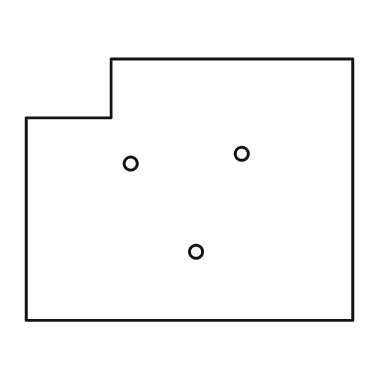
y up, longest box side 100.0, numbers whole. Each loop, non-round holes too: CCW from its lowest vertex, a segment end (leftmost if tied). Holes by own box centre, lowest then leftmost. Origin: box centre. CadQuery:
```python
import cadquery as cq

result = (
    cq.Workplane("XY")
    .moveTo(-50.0, -40.0)
    .lineTo(50.0, -40.0)
    .lineTo(50.0, 40.0)
    .lineTo(-24.0, 40.0)
    .lineTo(-24.0, 22.0)
    .lineTo(-50.0, 22.0)
    .close()
    .moveTo(2.0, -19.0)
    .circle(2.0)
    .moveTo(-18.0, 8.0)
    .circle(2.0)
    .moveTo(16.0, 11.0)
    .circle(2.0)
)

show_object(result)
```